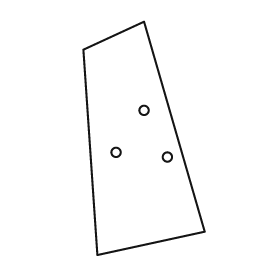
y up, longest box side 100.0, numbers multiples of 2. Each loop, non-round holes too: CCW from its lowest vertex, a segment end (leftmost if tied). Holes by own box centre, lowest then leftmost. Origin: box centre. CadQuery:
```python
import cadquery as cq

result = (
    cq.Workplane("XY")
    .moveTo(-20.0, -50.0)
    .lineTo(26.0, -40.0)
    .lineTo(0.0, 50.0)
    .lineTo(-26.0, 38.0)
    .close()
    .moveTo(10.0, -8.0)
    .circle(2.0)
    .moveTo(-12.0, -6.0)
    .circle(2.0)
    .moveTo(0.0, 12.0)
    .circle(2.0)
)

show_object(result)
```